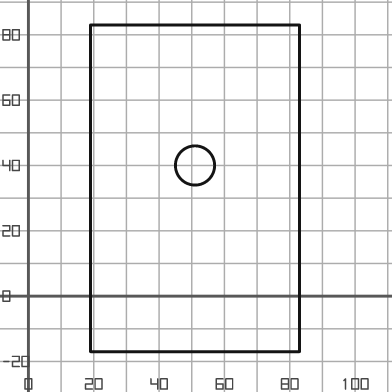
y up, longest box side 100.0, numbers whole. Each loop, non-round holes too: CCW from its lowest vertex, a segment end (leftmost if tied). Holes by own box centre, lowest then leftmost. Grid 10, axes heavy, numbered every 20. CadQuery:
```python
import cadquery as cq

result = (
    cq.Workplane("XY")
    .moveTo(19.0, -17.0)
    .lineTo(83.0, -17.0)
    .lineTo(83.0, 83.0)
    .lineTo(19.0, 83.0)
    .close()
    .moveTo(51.0, 40.0)
    .circle(6.0)
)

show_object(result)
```